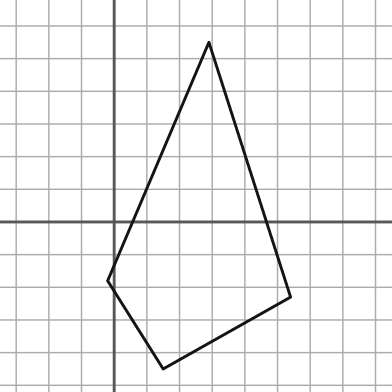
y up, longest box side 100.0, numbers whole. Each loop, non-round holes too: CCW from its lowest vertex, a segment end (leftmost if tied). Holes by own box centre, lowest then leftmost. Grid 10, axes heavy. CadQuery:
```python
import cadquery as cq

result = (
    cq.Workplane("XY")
    .moveTo(15.0, -45.0)
    .lineTo(54.0, -23.0)
    .lineTo(29.0, 55.0)
    .lineTo(-2.0, -18.0)
    .close()
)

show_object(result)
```